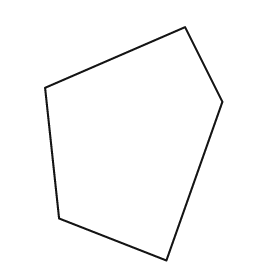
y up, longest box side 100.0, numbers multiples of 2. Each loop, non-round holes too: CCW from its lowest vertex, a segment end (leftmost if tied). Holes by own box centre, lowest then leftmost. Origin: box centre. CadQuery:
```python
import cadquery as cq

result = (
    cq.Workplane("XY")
    .moveTo(14.0, -50.0)
    .lineTo(38.0, 18.0)
    .lineTo(22.0, 50.0)
    .lineTo(-38.0, 24.0)
    .lineTo(-32.0, -32.0)
    .close()
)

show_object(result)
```